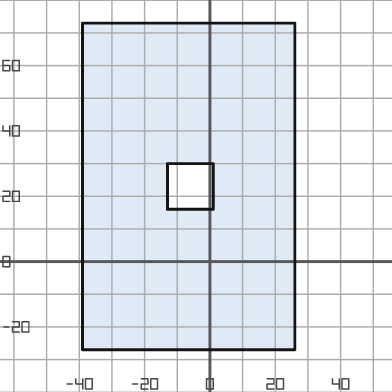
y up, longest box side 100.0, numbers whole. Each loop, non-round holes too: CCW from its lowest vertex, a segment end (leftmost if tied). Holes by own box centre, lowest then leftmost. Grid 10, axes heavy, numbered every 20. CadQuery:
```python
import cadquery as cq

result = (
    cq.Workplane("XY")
    .moveTo(-39.0, -27.0)
    .lineTo(26.0, -27.0)
    .lineTo(26.0, 73.0)
    .lineTo(-39.0, 73.0)
    .close()
    .moveTo(-13.0, 16.0)
    .lineTo(1.0, 16.0)
    .lineTo(1.0, 30.0)
    .lineTo(-13.0, 30.0)
    .close()
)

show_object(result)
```